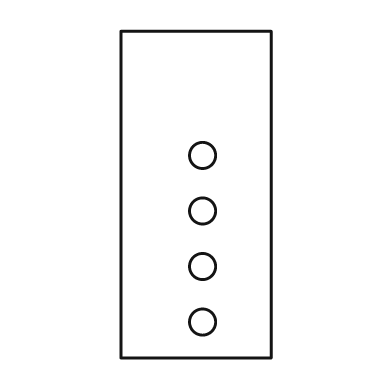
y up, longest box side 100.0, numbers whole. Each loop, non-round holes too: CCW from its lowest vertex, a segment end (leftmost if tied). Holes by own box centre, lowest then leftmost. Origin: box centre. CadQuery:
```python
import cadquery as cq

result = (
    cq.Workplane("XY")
    .moveTo(-23.0, -50.0)
    .lineTo(23.0, -50.0)
    .lineTo(23.0, 50.0)
    .lineTo(-23.0, 50.0)
    .close()
    .moveTo(2.0, -39.0)
    .circle(4.0)
    .moveTo(2.0, -22.0)
    .circle(4.0)
    .moveTo(2.0, -5.0)
    .circle(4.0)
    .moveTo(2.0, 12.0)
    .circle(4.0)
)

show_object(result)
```